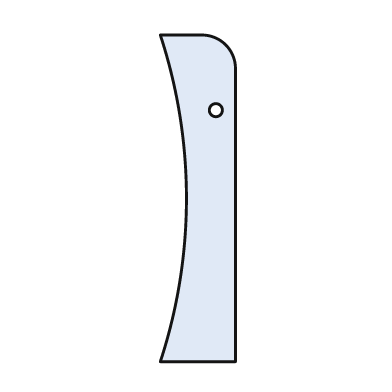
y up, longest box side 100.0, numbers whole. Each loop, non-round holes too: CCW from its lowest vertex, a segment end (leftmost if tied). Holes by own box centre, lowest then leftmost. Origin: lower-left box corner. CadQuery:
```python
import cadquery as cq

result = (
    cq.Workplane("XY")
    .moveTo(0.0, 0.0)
    .lineTo(23.0, 0.0)
    .lineTo(23.0, 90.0)
    .threePointArc((20.0, 97.0), (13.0, 100.0))
    .lineTo(0.0, 100.0)
    .threePointArc((8.0, 50.0), (0.0, 0.0))
    .close()
    .moveTo(17.0, 77.0)
    .circle(2.0)
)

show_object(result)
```